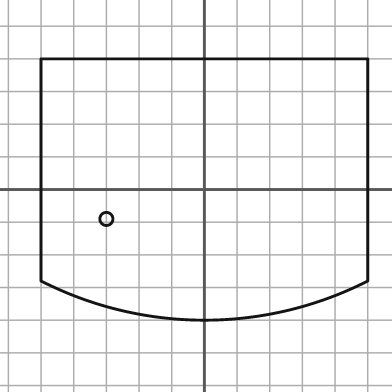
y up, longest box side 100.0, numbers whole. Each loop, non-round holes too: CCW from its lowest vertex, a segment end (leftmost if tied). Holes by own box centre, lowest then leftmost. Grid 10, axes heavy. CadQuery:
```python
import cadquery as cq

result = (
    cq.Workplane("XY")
    .moveTo(-50.0, -28.0)
    .threePointArc((0.0, -40.0), (50.0, -28.0))
    .lineTo(50.0, 40.0)
    .lineTo(-50.0, 40.0)
    .close()
    .moveTo(-30.0, -9.0)
    .circle(2.0)
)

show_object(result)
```